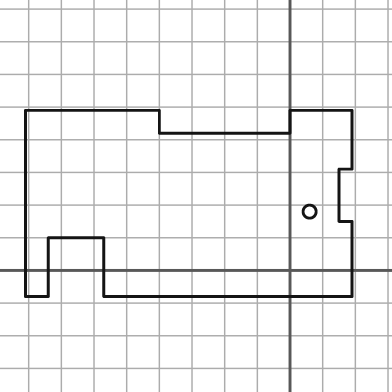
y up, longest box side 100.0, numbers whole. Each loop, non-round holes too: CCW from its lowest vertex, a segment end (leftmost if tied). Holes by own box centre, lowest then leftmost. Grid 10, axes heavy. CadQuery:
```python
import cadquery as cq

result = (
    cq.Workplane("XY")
    .moveTo(-81.0, -8.0)
    .lineTo(-74.0, -8.0)
    .lineTo(-74.0, 10.0)
    .lineTo(-57.0, 10.0)
    .lineTo(-57.0, -8.0)
    .lineTo(19.0, -8.0)
    .lineTo(19.0, 15.0)
    .lineTo(15.0, 15.0)
    .lineTo(15.0, 31.0)
    .lineTo(19.0, 31.0)
    .lineTo(19.0, 49.0)
    .lineTo(0.0, 49.0)
    .lineTo(0.0, 42.0)
    .lineTo(-40.0, 42.0)
    .lineTo(-40.0, 49.0)
    .lineTo(-81.0, 49.0)
    .close()
    .moveTo(6.0, 18.0)
    .circle(2.0)
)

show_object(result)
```